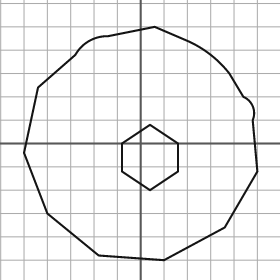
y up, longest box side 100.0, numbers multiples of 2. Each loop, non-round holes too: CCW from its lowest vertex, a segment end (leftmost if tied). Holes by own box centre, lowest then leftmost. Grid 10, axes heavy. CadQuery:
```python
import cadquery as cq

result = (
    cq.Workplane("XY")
    .moveTo(10.0, -50.0)
    .lineTo(36.0, -36.0)
    .lineTo(50.0, -12.0)
    .lineTo(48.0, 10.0)
    .threePointArc((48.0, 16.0), (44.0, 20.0))
    .lineTo(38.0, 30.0)
    .threePointArc((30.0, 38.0), (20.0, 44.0))
    .lineTo(6.0, 50.0)
    .lineTo(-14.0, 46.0)
    .threePointArc((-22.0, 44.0), (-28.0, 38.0))
    .lineTo(-44.0, 24.0)
    .lineTo(-50.0, -4.0)
    .lineTo(-40.0, -30.0)
    .lineTo(-18.0, -48.0)
    .close()
    .moveTo(4.0, -20.0)
    .lineTo(16.0, -12.0)
    .lineTo(16.0, 0.0)
    .lineTo(4.0, 8.0)
    .lineTo(-8.0, 0.0)
    .lineTo(-8.0, -12.0)
    .close()
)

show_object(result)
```